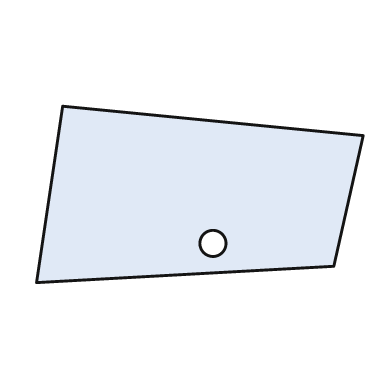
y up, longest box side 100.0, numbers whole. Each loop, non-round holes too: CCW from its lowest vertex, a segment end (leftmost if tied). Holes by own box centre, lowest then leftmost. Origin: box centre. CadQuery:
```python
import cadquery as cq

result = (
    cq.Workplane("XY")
    .moveTo(-50.0, -27.0)
    .lineTo(41.0, -22.0)
    .lineTo(50.0, 18.0)
    .lineTo(-42.0, 27.0)
    .close()
    .moveTo(4.0, -15.0)
    .circle(4.0)
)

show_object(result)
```